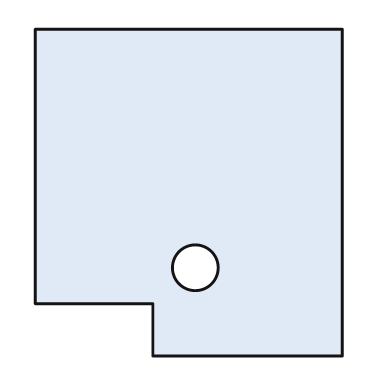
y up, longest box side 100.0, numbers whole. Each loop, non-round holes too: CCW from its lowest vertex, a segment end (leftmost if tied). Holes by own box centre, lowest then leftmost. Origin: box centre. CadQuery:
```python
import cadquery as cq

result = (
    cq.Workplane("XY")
    .moveTo(-11.0, -50.0)
    .lineTo(47.0, -50.0)
    .lineTo(47.0, 50.0)
    .lineTo(-47.0, 50.0)
    .lineTo(-47.0, -34.0)
    .lineTo(-11.0, -34.0)
    .close()
    .moveTo(2.0, -23.0)
    .circle(7.0)
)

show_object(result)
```